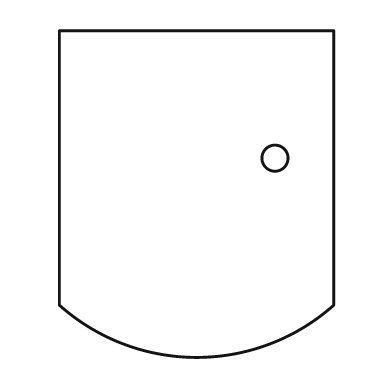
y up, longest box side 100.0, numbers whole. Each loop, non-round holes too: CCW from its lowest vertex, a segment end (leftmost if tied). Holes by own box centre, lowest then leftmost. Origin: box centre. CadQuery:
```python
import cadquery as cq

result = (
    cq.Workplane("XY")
    .moveTo(-42.0, -34.0)
    .threePointArc((0.0, -50.0), (42.0, -34.0))
    .lineTo(42.0, 50.0)
    .lineTo(-42.0, 50.0)
    .close()
    .moveTo(24.0, 11.0)
    .circle(4.0)
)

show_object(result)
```